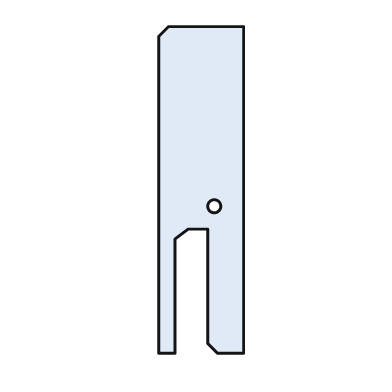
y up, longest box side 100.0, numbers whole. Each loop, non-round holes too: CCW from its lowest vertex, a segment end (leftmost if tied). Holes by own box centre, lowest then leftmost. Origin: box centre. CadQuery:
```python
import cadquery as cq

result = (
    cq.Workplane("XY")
    .moveTo(-13.0, -50.0)
    .lineTo(-8.0, -50.0)
    .lineTo(-8.0, -15.0)
    .lineTo(-4.0, -12.0)
    .lineTo(2.0, -12.0)
    .lineTo(2.0, -47.0)
    .lineTo(5.0, -50.0)
    .lineTo(13.0, -50.0)
    .lineTo(13.0, 50.0)
    .lineTo(-10.0, 50.0)
    .lineTo(-13.0, 47.0)
    .close()
    .moveTo(4.0, -5.0)
    .circle(2.0)
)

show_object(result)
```